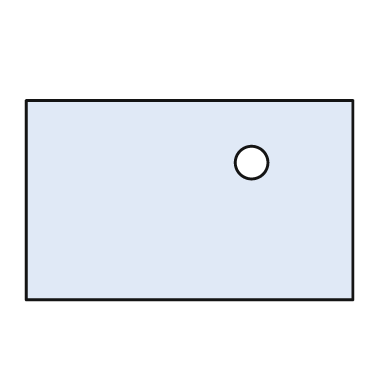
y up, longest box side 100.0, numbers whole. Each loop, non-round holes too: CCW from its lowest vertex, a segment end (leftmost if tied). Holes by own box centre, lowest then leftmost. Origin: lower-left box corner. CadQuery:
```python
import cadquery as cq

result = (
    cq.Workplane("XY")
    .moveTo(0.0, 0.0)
    .lineTo(100.0, 0.0)
    .lineTo(100.0, 61.0)
    .lineTo(0.0, 61.0)
    .close()
    .moveTo(69.0, 42.0)
    .circle(5.0)
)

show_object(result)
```